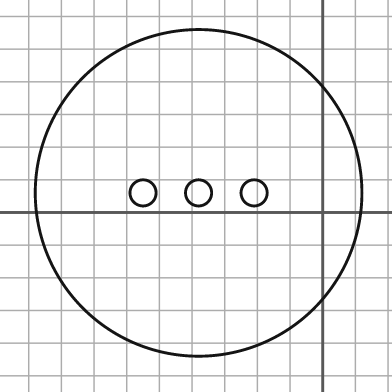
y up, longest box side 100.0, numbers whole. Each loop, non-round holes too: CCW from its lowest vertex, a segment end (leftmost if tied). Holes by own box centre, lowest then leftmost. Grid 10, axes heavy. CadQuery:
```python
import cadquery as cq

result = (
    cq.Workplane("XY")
    .moveTo(-38.0, 6.0)
    .circle(50.0)
    .moveTo(-55.0, 6.0)
    .circle(4.0)
    .moveTo(-38.0, 6.0)
    .circle(4.0)
    .moveTo(-21.0, 6.0)
    .circle(4.0)
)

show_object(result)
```